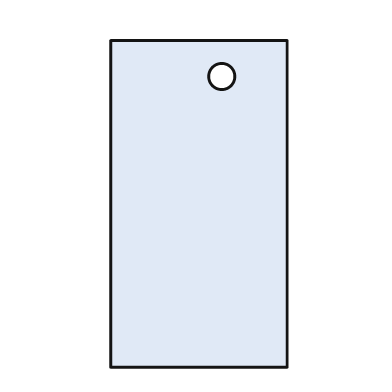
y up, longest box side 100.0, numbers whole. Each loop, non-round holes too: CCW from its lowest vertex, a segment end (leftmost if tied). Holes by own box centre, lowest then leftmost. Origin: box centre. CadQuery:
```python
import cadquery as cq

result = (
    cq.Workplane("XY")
    .moveTo(-27.0, -50.0)
    .lineTo(27.0, -50.0)
    .lineTo(27.0, 50.0)
    .lineTo(-27.0, 50.0)
    .close()
    .moveTo(7.0, 39.0)
    .circle(4.0)
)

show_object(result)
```